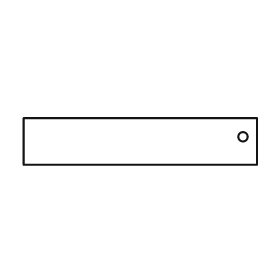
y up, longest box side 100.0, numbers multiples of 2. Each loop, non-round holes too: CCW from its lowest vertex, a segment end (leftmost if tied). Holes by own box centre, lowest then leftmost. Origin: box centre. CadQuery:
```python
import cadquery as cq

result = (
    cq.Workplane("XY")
    .moveTo(-50.0, -10.0)
    .lineTo(50.0, -10.0)
    .lineTo(50.0, 10.0)
    .lineTo(-50.0, 10.0)
    .close()
    .moveTo(44.0, 2.0)
    .circle(2.0)
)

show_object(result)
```